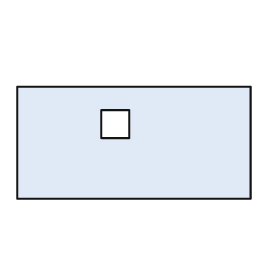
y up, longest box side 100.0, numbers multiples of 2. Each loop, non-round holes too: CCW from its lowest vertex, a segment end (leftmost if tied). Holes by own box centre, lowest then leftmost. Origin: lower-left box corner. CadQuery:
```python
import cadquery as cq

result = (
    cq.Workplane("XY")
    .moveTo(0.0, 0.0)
    .lineTo(100.0, 0.0)
    .lineTo(100.0, 48.0)
    .lineTo(0.0, 48.0)
    .close()
    .moveTo(36.0, 26.0)
    .lineTo(48.0, 26.0)
    .lineTo(48.0, 38.0)
    .lineTo(36.0, 38.0)
    .close()
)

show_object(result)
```